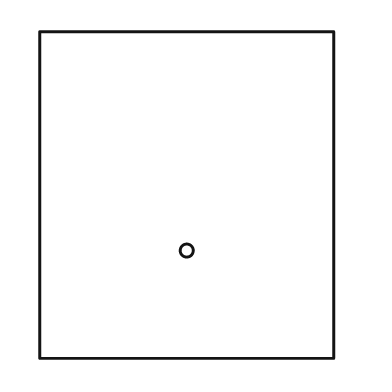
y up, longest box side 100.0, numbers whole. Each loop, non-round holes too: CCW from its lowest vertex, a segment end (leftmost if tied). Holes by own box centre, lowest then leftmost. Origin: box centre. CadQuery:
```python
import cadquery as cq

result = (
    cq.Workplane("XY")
    .moveTo(-45.0, -50.0)
    .lineTo(45.0, -50.0)
    .lineTo(45.0, 50.0)
    .lineTo(-45.0, 50.0)
    .close()
    .moveTo(0.0, -17.0)
    .circle(2.0)
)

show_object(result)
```